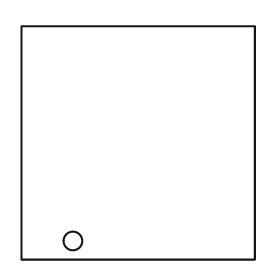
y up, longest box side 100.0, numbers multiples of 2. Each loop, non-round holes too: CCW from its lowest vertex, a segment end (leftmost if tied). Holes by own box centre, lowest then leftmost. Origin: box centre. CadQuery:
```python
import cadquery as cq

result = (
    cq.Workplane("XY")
    .moveTo(-50.0, -50.0)
    .lineTo(50.0, -50.0)
    .lineTo(50.0, 50.0)
    .lineTo(-50.0, 50.0)
    .close()
    .moveTo(-28.0, -42.0)
    .circle(4.0)
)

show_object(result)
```